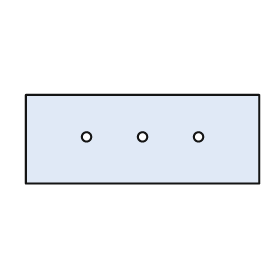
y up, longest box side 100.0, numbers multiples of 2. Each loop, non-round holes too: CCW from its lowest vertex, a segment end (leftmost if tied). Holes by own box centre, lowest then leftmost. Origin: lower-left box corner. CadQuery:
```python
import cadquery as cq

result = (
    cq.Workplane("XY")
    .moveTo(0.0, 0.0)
    .lineTo(100.0, 0.0)
    .lineTo(100.0, 38.0)
    .lineTo(0.0, 38.0)
    .close()
    .moveTo(26.0, 20.0)
    .circle(2.0)
    .moveTo(50.0, 20.0)
    .circle(2.0)
    .moveTo(74.0, 20.0)
    .circle(2.0)
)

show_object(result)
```